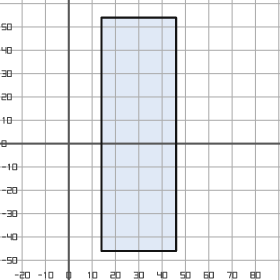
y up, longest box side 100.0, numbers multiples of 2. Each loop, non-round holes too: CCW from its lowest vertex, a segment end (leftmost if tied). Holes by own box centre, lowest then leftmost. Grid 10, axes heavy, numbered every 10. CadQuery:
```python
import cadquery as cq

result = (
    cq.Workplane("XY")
    .moveTo(14.0, -46.0)
    .lineTo(46.0, -46.0)
    .lineTo(46.0, 54.0)
    .lineTo(14.0, 54.0)
    .close()
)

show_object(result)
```